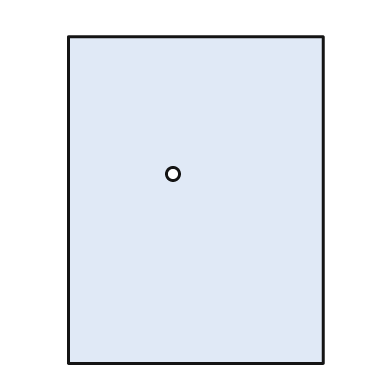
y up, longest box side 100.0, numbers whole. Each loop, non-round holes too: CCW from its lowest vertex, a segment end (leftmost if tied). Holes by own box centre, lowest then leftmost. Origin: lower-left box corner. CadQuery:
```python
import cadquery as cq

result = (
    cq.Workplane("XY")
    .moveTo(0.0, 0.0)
    .lineTo(78.0, 0.0)
    .lineTo(78.0, 100.0)
    .lineTo(0.0, 100.0)
    .close()
    .moveTo(32.0, 58.0)
    .circle(2.0)
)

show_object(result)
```